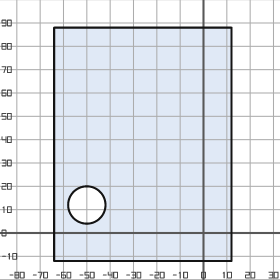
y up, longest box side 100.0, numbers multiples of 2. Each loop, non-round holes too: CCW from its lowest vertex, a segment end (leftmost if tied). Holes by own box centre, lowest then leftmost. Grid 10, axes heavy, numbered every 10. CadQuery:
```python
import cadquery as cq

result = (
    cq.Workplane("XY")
    .moveTo(-64.0, -12.0)
    .lineTo(12.0, -12.0)
    .lineTo(12.0, 88.0)
    .lineTo(-64.0, 88.0)
    .close()
    .moveTo(-50.0, 12.0)
    .circle(8.0)
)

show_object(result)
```